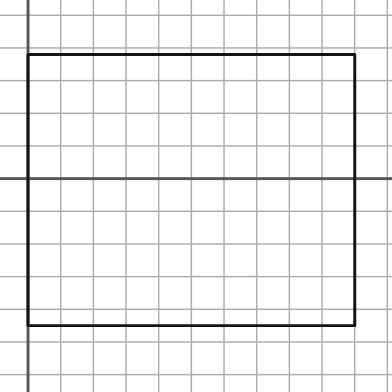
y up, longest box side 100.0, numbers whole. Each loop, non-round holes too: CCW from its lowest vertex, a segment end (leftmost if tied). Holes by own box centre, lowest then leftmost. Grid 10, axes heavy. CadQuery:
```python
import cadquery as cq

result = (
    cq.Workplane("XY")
    .moveTo(0.0, -45.0)
    .lineTo(100.0, -45.0)
    .lineTo(100.0, 38.0)
    .lineTo(0.0, 38.0)
    .close()
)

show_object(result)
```